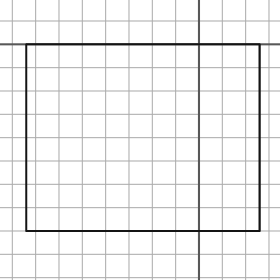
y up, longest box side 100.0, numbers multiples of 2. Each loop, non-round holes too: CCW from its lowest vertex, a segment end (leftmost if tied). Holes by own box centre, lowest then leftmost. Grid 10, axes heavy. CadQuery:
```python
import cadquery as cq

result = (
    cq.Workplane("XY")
    .moveTo(-74.0, -80.0)
    .lineTo(26.0, -80.0)
    .lineTo(26.0, 0.0)
    .lineTo(-74.0, 0.0)
    .close()
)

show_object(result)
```